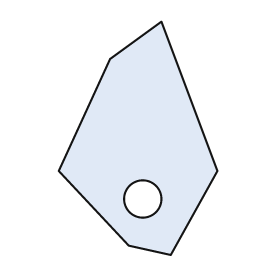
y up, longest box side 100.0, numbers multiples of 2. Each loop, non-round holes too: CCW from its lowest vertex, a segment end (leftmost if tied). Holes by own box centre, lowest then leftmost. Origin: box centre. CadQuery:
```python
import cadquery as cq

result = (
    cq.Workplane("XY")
    .moveTo(14.0, -50.0)
    .lineTo(34.0, -14.0)
    .lineTo(10.0, 50.0)
    .lineTo(-12.0, 34.0)
    .lineTo(-34.0, -14.0)
    .lineTo(-4.0, -46.0)
    .close()
    .moveTo(2.0, -26.0)
    .circle(8.0)
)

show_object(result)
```